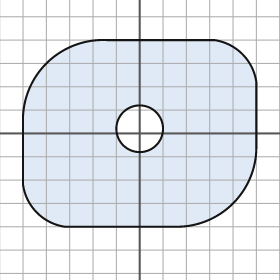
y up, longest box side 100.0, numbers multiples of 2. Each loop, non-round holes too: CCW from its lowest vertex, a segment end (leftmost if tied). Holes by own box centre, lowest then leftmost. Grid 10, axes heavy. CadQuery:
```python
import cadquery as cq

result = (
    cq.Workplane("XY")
    .moveTo(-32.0, -40.0)
    .lineTo(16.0, -40.0)
    .threePointArc((40.0, -30.0), (50.0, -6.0))
    .lineTo(50.0, 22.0)
    .threePointArc((44.0, 34.0), (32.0, 40.0))
    .lineTo(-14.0, 40.0)
    .threePointArc((-40.0, 30.0), (-50.0, 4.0))
    .lineTo(-50.0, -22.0)
    .threePointArc((-44.0, -34.0), (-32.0, -40.0))
    .close()
    .moveTo(0.0, 2.0)
    .circle(10.0)
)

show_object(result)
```